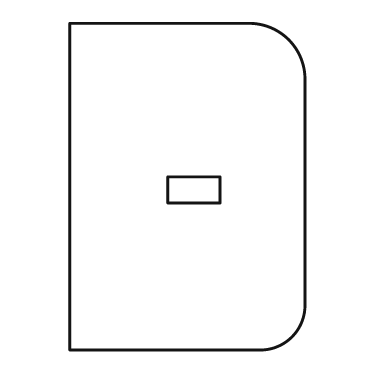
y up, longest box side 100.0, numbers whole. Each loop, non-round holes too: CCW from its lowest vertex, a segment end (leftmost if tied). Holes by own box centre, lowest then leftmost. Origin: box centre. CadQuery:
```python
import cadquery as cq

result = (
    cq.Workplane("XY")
    .moveTo(-36.0, -50.0)
    .lineTo(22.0, -50.0)
    .threePointArc((32.0, -46.0), (36.0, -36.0))
    .lineTo(36.0, 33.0)
    .threePointArc((31.0, 45.0), (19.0, 50.0))
    .lineTo(-36.0, 50.0)
    .close()
    .moveTo(-6.0, -5.0)
    .lineTo(10.0, -5.0)
    .lineTo(10.0, 3.0)
    .lineTo(-6.0, 3.0)
    .close()
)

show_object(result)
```